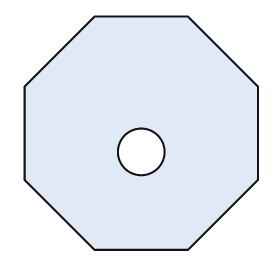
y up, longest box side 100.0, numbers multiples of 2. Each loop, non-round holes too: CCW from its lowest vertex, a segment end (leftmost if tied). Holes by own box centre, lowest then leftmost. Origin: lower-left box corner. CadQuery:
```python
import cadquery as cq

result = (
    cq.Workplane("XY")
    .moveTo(30.0, 0.0)
    .lineTo(70.0, 0.0)
    .lineTo(100.0, 30.0)
    .lineTo(100.0, 70.0)
    .lineTo(70.0, 100.0)
    .lineTo(30.0, 100.0)
    .lineTo(0.0, 70.0)
    .lineTo(0.0, 30.0)
    .close()
    .moveTo(50.0, 42.0)
    .circle(10.0)
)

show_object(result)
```